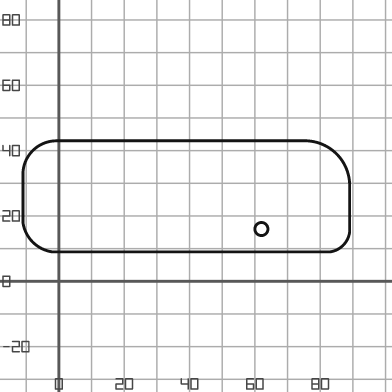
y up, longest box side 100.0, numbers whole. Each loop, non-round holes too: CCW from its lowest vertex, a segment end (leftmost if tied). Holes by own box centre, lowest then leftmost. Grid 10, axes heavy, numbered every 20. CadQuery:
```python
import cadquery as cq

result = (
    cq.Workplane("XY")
    .moveTo(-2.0, 9.0)
    .lineTo(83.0, 9.0)
    .threePointArc((87.0, 11.0), (89.0, 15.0))
    .lineTo(89.0, 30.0)
    .threePointArc((85.0, 39.0), (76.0, 43.0))
    .lineTo(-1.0, 43.0)
    .threePointArc((-8.0, 40.0), (-11.0, 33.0))
    .lineTo(-11.0, 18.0)
    .threePointArc((-8.0, 12.0), (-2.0, 9.0))
    .close()
    .moveTo(62.0, 16.0)
    .circle(2.0)
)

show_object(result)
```